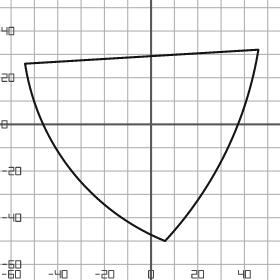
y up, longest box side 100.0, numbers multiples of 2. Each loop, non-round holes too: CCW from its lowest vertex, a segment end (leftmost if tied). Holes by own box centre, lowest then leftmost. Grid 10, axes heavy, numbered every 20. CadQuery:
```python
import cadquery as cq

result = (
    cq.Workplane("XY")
    .moveTo(6.0, -50.0)
    .threePointArc((32.0, -12.0), (46.0, 32.0))
    .lineTo(-54.0, 26.0)
    .threePointArc((-34.0, -20.0), (6.0, -50.0))
    .close()
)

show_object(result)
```